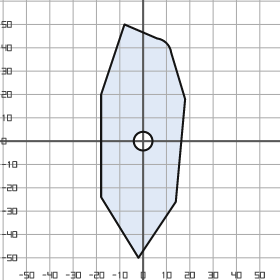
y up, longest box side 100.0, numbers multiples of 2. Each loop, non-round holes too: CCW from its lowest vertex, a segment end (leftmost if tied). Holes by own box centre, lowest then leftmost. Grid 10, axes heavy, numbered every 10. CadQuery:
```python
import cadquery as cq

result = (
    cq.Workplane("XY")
    .moveTo(-2.0, -50.0)
    .lineTo(14.0, -26.0)
    .lineTo(18.0, 18.0)
    .lineTo(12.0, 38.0)
    .threePointArc((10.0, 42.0), (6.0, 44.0))
    .lineTo(-8.0, 50.0)
    .lineTo(-18.0, 20.0)
    .lineTo(-18.0, -24.0)
    .close()
    .moveTo(0.0, 0.0)
    .circle(4.0)
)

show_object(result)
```